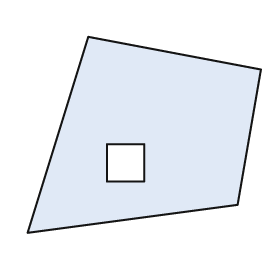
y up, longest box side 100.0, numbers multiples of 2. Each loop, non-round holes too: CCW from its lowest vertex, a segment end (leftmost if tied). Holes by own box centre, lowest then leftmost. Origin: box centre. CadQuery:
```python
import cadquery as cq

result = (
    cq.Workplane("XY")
    .moveTo(-50.0, -42.0)
    .lineTo(40.0, -30.0)
    .lineTo(50.0, 28.0)
    .lineTo(-24.0, 42.0)
    .close()
    .moveTo(-16.0, -20.0)
    .lineTo(0.0, -20.0)
    .lineTo(0.0, -4.0)
    .lineTo(-16.0, -4.0)
    .close()
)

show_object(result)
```